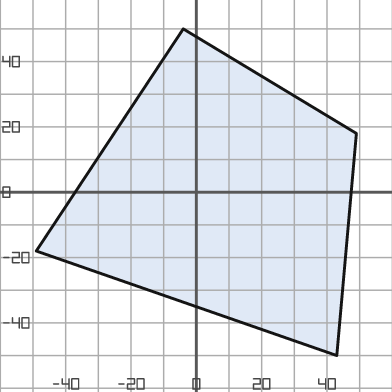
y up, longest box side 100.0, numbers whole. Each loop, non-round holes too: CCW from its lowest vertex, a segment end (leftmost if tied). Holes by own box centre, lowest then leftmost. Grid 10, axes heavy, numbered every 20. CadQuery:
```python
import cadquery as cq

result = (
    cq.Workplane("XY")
    .moveTo(43.0, -50.0)
    .lineTo(49.0, 18.0)
    .lineTo(-4.0, 50.0)
    .lineTo(-49.0, -18.0)
    .close()
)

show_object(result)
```